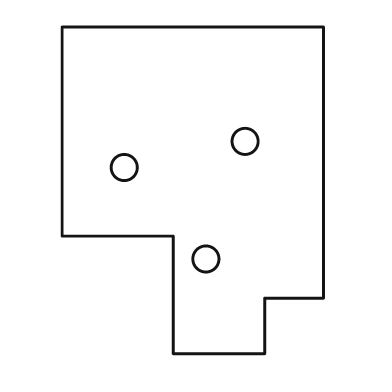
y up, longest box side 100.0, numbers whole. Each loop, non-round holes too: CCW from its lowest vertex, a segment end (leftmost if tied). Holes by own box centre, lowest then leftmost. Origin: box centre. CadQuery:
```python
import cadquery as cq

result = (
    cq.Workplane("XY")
    .moveTo(-6.0, -50.0)
    .lineTo(22.0, -50.0)
    .lineTo(22.0, -33.0)
    .lineTo(40.0, -33.0)
    .lineTo(40.0, 50.0)
    .lineTo(-40.0, 50.0)
    .lineTo(-40.0, -14.0)
    .lineTo(-6.0, -14.0)
    .close()
    .moveTo(4.0, -21.0)
    .circle(4.0)
    .moveTo(-21.0, 7.0)
    .circle(4.0)
    .moveTo(16.0, 15.0)
    .circle(4.0)
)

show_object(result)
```